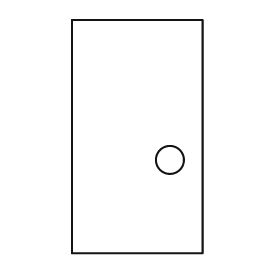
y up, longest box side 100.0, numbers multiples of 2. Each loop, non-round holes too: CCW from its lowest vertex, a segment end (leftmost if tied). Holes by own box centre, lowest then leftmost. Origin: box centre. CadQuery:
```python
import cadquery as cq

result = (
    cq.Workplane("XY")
    .moveTo(-28.0, -50.0)
    .lineTo(28.0, -50.0)
    .lineTo(28.0, 50.0)
    .lineTo(-28.0, 50.0)
    .close()
    .moveTo(14.0, -10.0)
    .circle(6.0)
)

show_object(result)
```